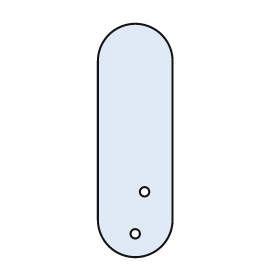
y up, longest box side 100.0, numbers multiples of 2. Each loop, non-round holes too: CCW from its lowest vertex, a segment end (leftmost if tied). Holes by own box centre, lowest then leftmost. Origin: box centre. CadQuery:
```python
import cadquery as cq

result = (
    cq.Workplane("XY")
    .moveTo(-16.0, -34.0)
    .threePointArc((0.0, -50.0), (16.0, -34.0))
    .lineTo(16.0, 34.0)
    .threePointArc((0.0, 50.0), (-16.0, 34.0))
    .close()
    .moveTo(0.0, -40.0)
    .circle(2.0)
    .moveTo(4.0, -22.0)
    .circle(2.0)
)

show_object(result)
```